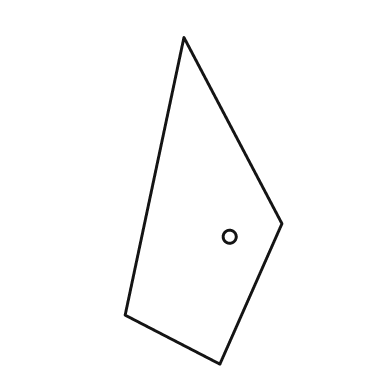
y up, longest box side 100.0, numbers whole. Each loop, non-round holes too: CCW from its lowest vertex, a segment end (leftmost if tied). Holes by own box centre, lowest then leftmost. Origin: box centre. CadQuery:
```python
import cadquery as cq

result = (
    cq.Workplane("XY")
    .moveTo(5.0, -50.0)
    .lineTo(24.0, -7.0)
    .lineTo(-6.0, 50.0)
    .lineTo(-24.0, -35.0)
    .close()
    .moveTo(8.0, -11.0)
    .circle(2.0)
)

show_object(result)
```